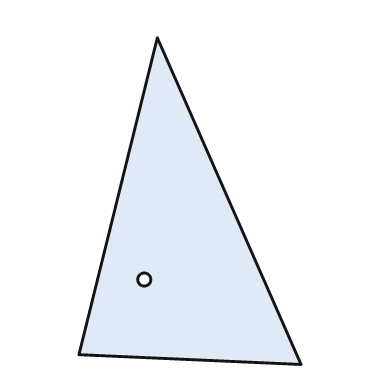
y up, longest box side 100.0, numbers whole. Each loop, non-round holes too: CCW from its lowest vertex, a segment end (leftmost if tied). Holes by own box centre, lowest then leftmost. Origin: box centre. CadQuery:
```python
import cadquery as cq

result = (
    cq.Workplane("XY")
    .moveTo(34.0, -50.0)
    .lineTo(-10.0, 50.0)
    .lineTo(-34.0, -47.0)
    .close()
    .moveTo(-14.0, -24.0)
    .circle(2.0)
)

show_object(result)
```